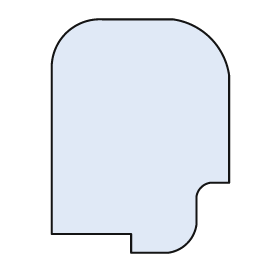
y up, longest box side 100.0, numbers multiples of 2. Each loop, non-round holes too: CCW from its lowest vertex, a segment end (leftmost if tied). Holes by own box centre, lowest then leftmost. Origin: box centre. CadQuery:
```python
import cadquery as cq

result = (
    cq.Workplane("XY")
    .moveTo(-4.0, -50.0)
    .lineTo(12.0, -50.0)
    .threePointArc((20.0, -46.0), (24.0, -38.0))
    .lineTo(24.0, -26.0)
    .threePointArc((26.0, -22.0), (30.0, -20.0))
    .lineTo(38.0, -20.0)
    .lineTo(38.0, 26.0)
    .threePointArc((30.0, 42.0), (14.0, 50.0))
    .lineTo(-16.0, 50.0)
    .threePointArc((-32.0, 44.0), (-38.0, 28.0))
    .lineTo(-38.0, -42.0)
    .lineTo(-4.0, -42.0)
    .close()
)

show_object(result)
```